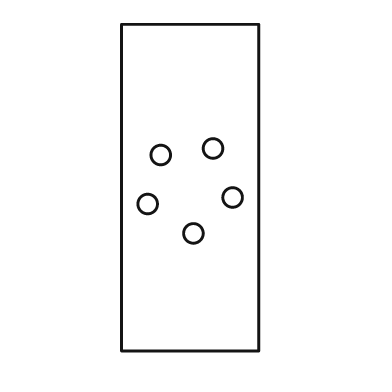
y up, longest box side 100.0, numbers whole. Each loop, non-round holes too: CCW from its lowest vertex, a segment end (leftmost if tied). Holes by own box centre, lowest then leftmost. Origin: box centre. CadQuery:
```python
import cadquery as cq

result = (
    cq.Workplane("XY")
    .moveTo(-21.0, -50.0)
    .lineTo(21.0, -50.0)
    .lineTo(21.0, 50.0)
    .lineTo(-21.0, 50.0)
    .close()
    .moveTo(1.0, -14.0)
    .circle(3.0)
    .moveTo(-13.0, -5.0)
    .circle(3.0)
    .moveTo(13.0, -3.0)
    .circle(3.0)
    .moveTo(-9.0, 10.0)
    .circle(3.0)
    .moveTo(7.0, 12.0)
    .circle(3.0)
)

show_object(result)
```